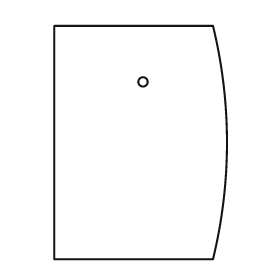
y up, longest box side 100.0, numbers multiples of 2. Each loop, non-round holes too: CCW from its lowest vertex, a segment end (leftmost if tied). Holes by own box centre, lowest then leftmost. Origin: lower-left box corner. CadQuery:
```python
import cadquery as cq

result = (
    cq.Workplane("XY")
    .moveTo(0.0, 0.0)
    .lineTo(68.0, 0.0)
    .threePointArc((74.0, 50.0), (68.0, 100.0))
    .lineTo(0.0, 100.0)
    .close()
    .moveTo(38.0, 76.0)
    .circle(2.0)
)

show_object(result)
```